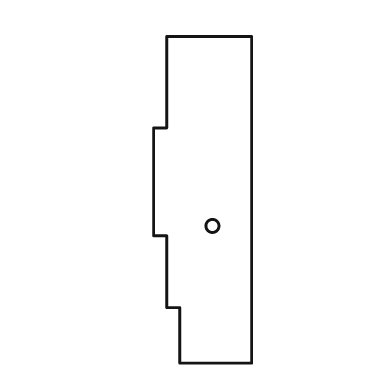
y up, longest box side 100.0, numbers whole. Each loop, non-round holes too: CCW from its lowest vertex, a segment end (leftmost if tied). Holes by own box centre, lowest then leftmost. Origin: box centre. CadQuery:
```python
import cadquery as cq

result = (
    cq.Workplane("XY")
    .moveTo(-7.0, -50.0)
    .lineTo(15.0, -50.0)
    .lineTo(15.0, 50.0)
    .lineTo(-11.0, 50.0)
    .lineTo(-11.0, 22.0)
    .lineTo(-15.0, 22.0)
    .lineTo(-15.0, -11.0)
    .lineTo(-11.0, -11.0)
    .lineTo(-11.0, -33.0)
    .lineTo(-7.0, -33.0)
    .close()
    .moveTo(3.0, -8.0)
    .circle(2.0)
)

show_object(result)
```